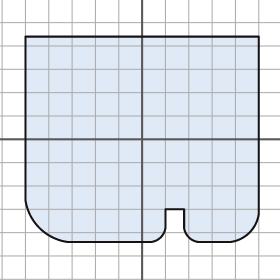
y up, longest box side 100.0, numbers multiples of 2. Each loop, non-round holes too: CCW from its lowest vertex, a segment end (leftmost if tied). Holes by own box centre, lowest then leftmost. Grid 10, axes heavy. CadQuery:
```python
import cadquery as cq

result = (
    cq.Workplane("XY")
    .moveTo(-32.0, -44.0)
    .lineTo(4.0, -44.0)
    .threePointArc((8.0, -42.0), (10.0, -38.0))
    .lineTo(10.0, -30.0)
    .lineTo(18.0, -30.0)
    .lineTo(18.0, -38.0)
    .threePointArc((20.0, -42.0), (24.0, -44.0))
    .lineTo(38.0, -44.0)
    .threePointArc((46.0, -40.0), (50.0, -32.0))
    .lineTo(50.0, 44.0)
    .lineTo(-50.0, 44.0)
    .lineTo(-50.0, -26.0)
    .threePointArc((-44.0, -38.0), (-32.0, -44.0))
    .close()
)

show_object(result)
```